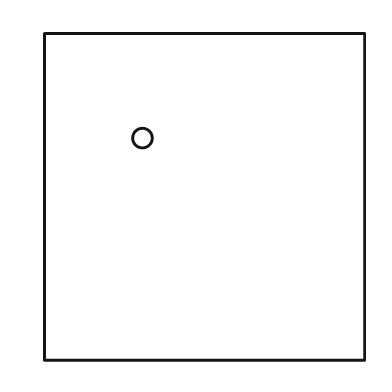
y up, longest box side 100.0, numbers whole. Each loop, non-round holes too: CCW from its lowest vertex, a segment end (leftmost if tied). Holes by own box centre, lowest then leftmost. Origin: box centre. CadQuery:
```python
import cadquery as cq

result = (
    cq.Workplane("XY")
    .moveTo(-49.0, -50.0)
    .lineTo(49.0, -50.0)
    .lineTo(49.0, 50.0)
    .lineTo(-49.0, 50.0)
    .close()
    .moveTo(-19.0, 18.0)
    .circle(3.0)
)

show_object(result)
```